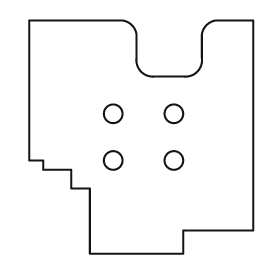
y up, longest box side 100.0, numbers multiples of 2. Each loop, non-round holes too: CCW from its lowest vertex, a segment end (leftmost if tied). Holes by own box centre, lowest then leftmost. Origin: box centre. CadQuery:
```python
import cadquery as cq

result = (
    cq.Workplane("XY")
    .moveTo(-22.0, -50.0)
    .lineTo(18.0, -50.0)
    .lineTo(18.0, -40.0)
    .lineTo(48.0, -40.0)
    .lineTo(48.0, 50.0)
    .lineTo(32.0, 50.0)
    .threePointArc((28.0, 48.0), (26.0, 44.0))
    .lineTo(26.0, 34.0)
    .threePointArc((24.0, 28.0), (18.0, 26.0))
    .lineTo(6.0, 26.0)
    .threePointArc((0.0, 28.0), (-2.0, 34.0))
    .lineTo(-2.0, 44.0)
    .threePointArc((-4.0, 48.0), (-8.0, 50.0))
    .lineTo(-48.0, 50.0)
    .lineTo(-48.0, -10.0)
    .lineTo(-42.0, -10.0)
    .lineTo(-42.0, -14.0)
    .lineTo(-30.0, -14.0)
    .lineTo(-30.0, -22.0)
    .lineTo(-22.0, -22.0)
    .close()
    .moveTo(-12.0, -10.0)
    .circle(4.0)
    .moveTo(14.0, -10.0)
    .circle(4.0)
    .moveTo(-12.0, 10.0)
    .circle(4.0)
    .moveTo(14.0, 10.0)
    .circle(4.0)
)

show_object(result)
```